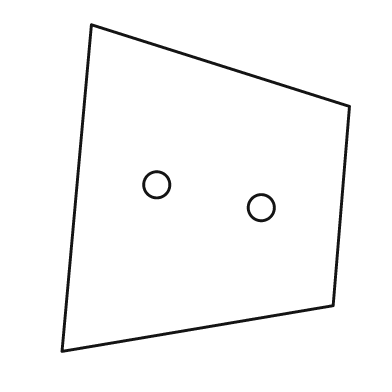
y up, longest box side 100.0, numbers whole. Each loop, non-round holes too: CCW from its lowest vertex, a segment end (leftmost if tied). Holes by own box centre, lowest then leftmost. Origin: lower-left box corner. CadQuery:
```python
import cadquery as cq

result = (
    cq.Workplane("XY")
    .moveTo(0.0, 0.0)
    .lineTo(83.0, 14.0)
    .lineTo(88.0, 75.0)
    .lineTo(9.0, 100.0)
    .close()
    .moveTo(61.0, 44.0)
    .circle(4.0)
    .moveTo(29.0, 51.0)
    .circle(4.0)
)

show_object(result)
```